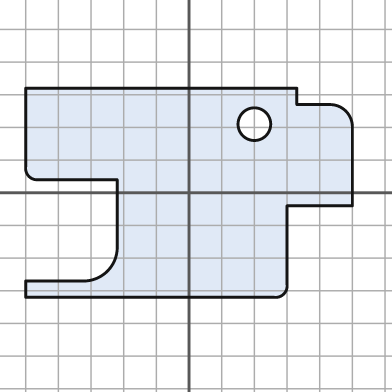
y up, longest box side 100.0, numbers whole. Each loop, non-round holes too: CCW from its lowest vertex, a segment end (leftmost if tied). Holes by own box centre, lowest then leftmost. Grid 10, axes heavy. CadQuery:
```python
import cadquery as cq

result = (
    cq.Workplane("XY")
    .moveTo(-50.0, -32.0)
    .lineTo(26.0, -32.0)
    .threePointArc((29.0, -31.0), (30.0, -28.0))
    .lineTo(30.0, -4.0)
    .lineTo(50.0, -4.0)
    .lineTo(50.0, 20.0)
    .threePointArc((48.0, 25.0), (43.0, 27.0))
    .lineTo(33.0, 27.0)
    .lineTo(33.0, 32.0)
    .lineTo(-50.0, 32.0)
    .lineTo(-50.0, 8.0)
    .threePointArc((-49.0, 5.0), (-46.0, 4.0))
    .lineTo(-22.0, 4.0)
    .lineTo(-22.0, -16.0)
    .threePointArc((-25.0, -24.0), (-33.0, -27.0))
    .lineTo(-50.0, -27.0)
    .close()
    .moveTo(20.0, 21.0)
    .circle(5.0)
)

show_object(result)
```